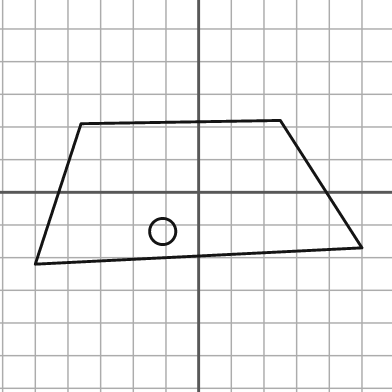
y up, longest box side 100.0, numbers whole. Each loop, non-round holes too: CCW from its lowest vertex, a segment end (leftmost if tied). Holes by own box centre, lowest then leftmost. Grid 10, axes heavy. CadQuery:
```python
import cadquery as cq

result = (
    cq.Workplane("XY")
    .moveTo(-50.0, -22.0)
    .lineTo(50.0, -17.0)
    .lineTo(25.0, 22.0)
    .lineTo(-36.0, 21.0)
    .close()
    .moveTo(-11.0, -12.0)
    .circle(4.0)
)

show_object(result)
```